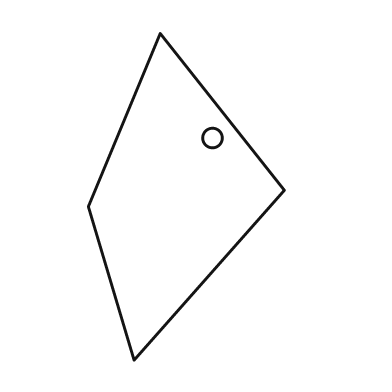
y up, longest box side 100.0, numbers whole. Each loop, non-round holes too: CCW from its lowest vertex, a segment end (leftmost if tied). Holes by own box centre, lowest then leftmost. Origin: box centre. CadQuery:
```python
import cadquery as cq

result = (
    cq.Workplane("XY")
    .moveTo(-16.0, -50.0)
    .lineTo(30.0, 2.0)
    .lineTo(-8.0, 50.0)
    .lineTo(-30.0, -3.0)
    .close()
    .moveTo(8.0, 18.0)
    .circle(3.0)
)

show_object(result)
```